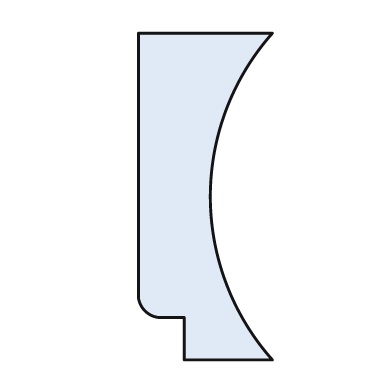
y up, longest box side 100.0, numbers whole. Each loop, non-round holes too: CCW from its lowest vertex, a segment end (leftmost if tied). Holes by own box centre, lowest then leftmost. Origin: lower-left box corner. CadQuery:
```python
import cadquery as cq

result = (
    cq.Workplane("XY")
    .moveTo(14.0, 0.0)
    .lineTo(41.0, 0.0)
    .threePointArc((22.0, 50.0), (41.0, 100.0))
    .lineTo(0.0, 100.0)
    .lineTo(0.0, 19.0)
    .threePointArc((2.0, 15.0), (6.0, 13.0))
    .lineTo(14.0, 13.0)
    .close()
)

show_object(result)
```